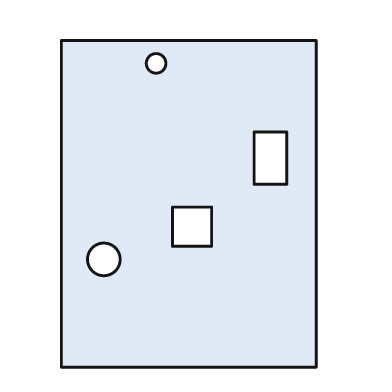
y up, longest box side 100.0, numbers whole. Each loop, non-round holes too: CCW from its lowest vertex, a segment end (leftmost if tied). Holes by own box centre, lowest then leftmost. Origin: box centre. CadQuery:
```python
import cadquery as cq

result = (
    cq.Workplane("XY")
    .moveTo(-39.0, -50.0)
    .lineTo(39.0, -50.0)
    .lineTo(39.0, 50.0)
    .lineTo(-39.0, 50.0)
    .close()
    .moveTo(-26.0, -17.0)
    .circle(5.0)
    .moveTo(-5.0, -13.0)
    .lineTo(7.0, -13.0)
    .lineTo(7.0, -1.0)
    .lineTo(-5.0, -1.0)
    .close()
    .moveTo(20.0, 6.0)
    .lineTo(30.0, 6.0)
    .lineTo(30.0, 22.0)
    .lineTo(20.0, 22.0)
    .close()
    .moveTo(-10.0, 43.0)
    .circle(3.0)
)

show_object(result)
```